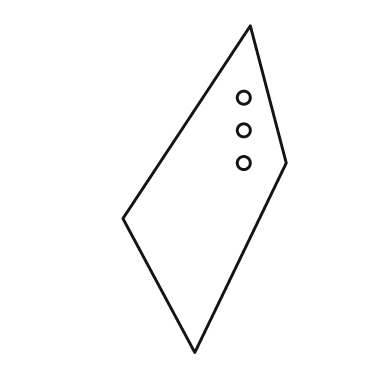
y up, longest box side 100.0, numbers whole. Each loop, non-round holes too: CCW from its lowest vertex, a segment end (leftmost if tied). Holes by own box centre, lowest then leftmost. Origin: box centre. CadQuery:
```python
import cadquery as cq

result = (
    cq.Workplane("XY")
    .moveTo(-3.0, -50.0)
    .lineTo(25.0, 8.0)
    .lineTo(14.0, 50.0)
    .lineTo(-25.0, -9.0)
    .close()
    .moveTo(12.0, 8.0)
    .circle(2.0)
    .moveTo(12.0, 18.0)
    .circle(2.0)
    .moveTo(12.0, 28.0)
    .circle(2.0)
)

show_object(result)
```